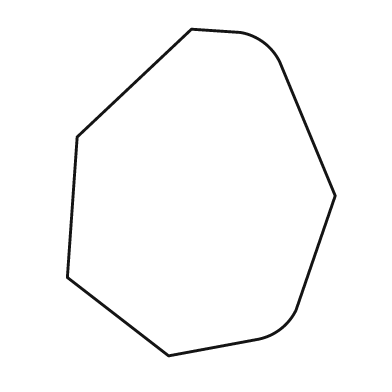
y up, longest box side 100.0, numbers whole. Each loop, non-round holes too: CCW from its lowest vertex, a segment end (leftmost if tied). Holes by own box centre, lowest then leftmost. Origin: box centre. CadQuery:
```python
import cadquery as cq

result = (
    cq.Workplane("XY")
    .moveTo(-10.0, -50.0)
    .lineTo(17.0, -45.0)
    .threePointArc((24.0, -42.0), (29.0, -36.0))
    .lineTo(41.0, -1.0)
    .lineTo(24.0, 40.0)
    .threePointArc((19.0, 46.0), (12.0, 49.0))
    .lineTo(-3.0, 50.0)
    .lineTo(-38.0, 17.0)
    .lineTo(-41.0, -26.0)
    .close()
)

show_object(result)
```